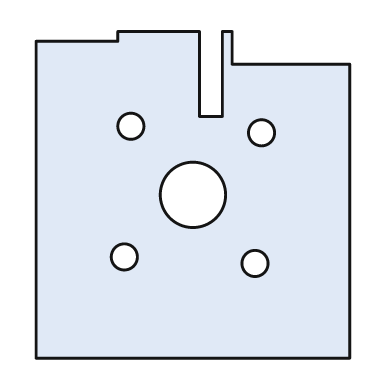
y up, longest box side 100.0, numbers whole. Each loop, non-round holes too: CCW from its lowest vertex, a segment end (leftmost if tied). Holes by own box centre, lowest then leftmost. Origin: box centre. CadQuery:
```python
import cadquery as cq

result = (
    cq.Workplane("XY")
    .moveTo(-48.0, -50.0)
    .lineTo(48.0, -50.0)
    .lineTo(48.0, 40.0)
    .lineTo(12.0, 40.0)
    .lineTo(12.0, 50.0)
    .lineTo(9.0, 50.0)
    .lineTo(9.0, 24.0)
    .lineTo(2.0, 24.0)
    .lineTo(2.0, 50.0)
    .lineTo(-23.0, 50.0)
    .lineTo(-23.0, 47.0)
    .lineTo(-48.0, 47.0)
    .close()
    .moveTo(19.0, -21.0)
    .circle(4.0)
    .moveTo(-21.0, -19.0)
    .circle(4.0)
    .moveTo(0.0, 0.0)
    .circle(10.0)
    .moveTo(21.0, 19.0)
    .circle(4.0)
    .moveTo(-19.0, 21.0)
    .circle(4.0)
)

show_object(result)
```